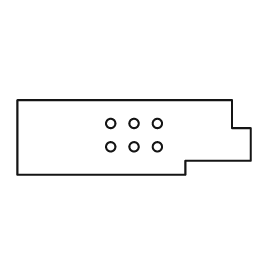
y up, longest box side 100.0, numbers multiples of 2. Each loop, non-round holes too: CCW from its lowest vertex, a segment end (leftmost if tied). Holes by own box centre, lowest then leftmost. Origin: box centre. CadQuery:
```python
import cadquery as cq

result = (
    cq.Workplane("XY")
    .moveTo(-50.0, -16.0)
    .lineTo(22.0, -16.0)
    .lineTo(22.0, -10.0)
    .lineTo(50.0, -10.0)
    .lineTo(50.0, 4.0)
    .lineTo(42.0, 4.0)
    .lineTo(42.0, 16.0)
    .lineTo(-50.0, 16.0)
    .close()
    .moveTo(-10.0, -4.0)
    .circle(2.0)
    .moveTo(0.0, -4.0)
    .circle(2.0)
    .moveTo(10.0, -4.0)
    .circle(2.0)
    .moveTo(-10.0, 6.0)
    .circle(2.0)
    .moveTo(0.0, 6.0)
    .circle(2.0)
    .moveTo(10.0, 6.0)
    .circle(2.0)
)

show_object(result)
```